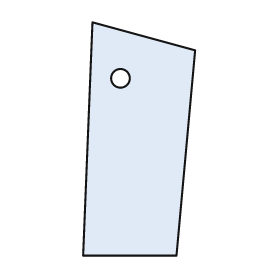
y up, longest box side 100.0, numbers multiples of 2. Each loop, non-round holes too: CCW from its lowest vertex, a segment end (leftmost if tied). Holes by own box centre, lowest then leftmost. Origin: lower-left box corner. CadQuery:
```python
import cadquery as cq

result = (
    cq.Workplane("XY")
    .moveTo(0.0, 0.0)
    .lineTo(40.0, 0.0)
    .lineTo(48.0, 88.0)
    .lineTo(4.0, 100.0)
    .close()
    .moveTo(16.0, 76.0)
    .circle(4.0)
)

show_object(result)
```